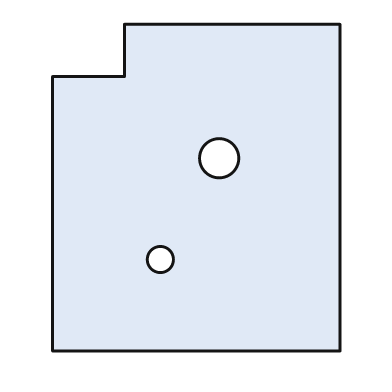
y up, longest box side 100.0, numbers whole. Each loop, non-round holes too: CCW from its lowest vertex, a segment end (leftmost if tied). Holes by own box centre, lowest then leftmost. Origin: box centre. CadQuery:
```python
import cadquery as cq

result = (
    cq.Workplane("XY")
    .moveTo(-44.0, -50.0)
    .lineTo(44.0, -50.0)
    .lineTo(44.0, 50.0)
    .lineTo(-22.0, 50.0)
    .lineTo(-22.0, 34.0)
    .lineTo(-44.0, 34.0)
    .close()
    .moveTo(-11.0, -22.0)
    .circle(4.0)
    .moveTo(7.0, 9.0)
    .circle(6.0)
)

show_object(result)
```